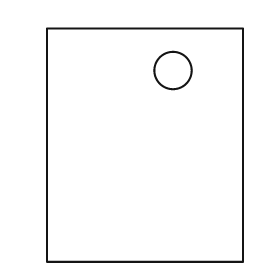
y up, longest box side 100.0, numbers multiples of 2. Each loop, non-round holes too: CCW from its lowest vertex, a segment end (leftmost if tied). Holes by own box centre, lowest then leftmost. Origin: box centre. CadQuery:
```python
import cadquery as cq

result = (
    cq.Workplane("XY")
    .moveTo(-42.0, -50.0)
    .lineTo(42.0, -50.0)
    .lineTo(42.0, 50.0)
    .lineTo(-42.0, 50.0)
    .close()
    .moveTo(12.0, 32.0)
    .circle(8.0)
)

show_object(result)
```